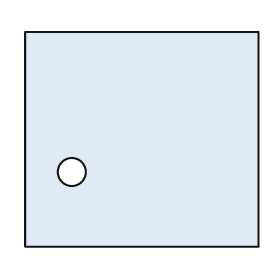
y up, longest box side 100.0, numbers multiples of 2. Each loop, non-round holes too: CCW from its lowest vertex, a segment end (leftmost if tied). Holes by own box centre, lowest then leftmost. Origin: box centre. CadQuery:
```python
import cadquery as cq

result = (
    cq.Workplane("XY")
    .moveTo(-50.0, -46.0)
    .lineTo(50.0, -46.0)
    .lineTo(50.0, 46.0)
    .lineTo(-50.0, 46.0)
    .close()
    .moveTo(-30.0, -14.0)
    .circle(6.0)
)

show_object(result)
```